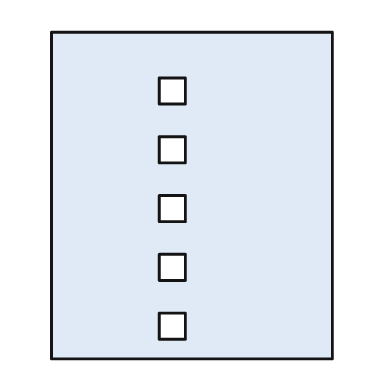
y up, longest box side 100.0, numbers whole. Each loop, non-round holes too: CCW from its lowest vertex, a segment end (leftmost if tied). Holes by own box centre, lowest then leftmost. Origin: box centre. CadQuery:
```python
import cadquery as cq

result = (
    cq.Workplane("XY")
    .moveTo(-43.0, -50.0)
    .lineTo(43.0, -50.0)
    .lineTo(43.0, 50.0)
    .lineTo(-43.0, 50.0)
    .close()
    .moveTo(-10.0, -44.0)
    .lineTo(-2.0, -44.0)
    .lineTo(-2.0, -36.0)
    .lineTo(-10.0, -36.0)
    .close()
    .moveTo(-10.0, -26.0)
    .lineTo(-2.0, -26.0)
    .lineTo(-2.0, -18.0)
    .lineTo(-10.0, -18.0)
    .close()
    .moveTo(-10.0, -8.0)
    .lineTo(-2.0, -8.0)
    .lineTo(-2.0, 0.0)
    .lineTo(-10.0, 0.0)
    .close()
    .moveTo(-10.0, 10.0)
    .lineTo(-2.0, 10.0)
    .lineTo(-2.0, 18.0)
    .lineTo(-10.0, 18.0)
    .close()
    .moveTo(-10.0, 28.0)
    .lineTo(-2.0, 28.0)
    .lineTo(-2.0, 36.0)
    .lineTo(-10.0, 36.0)
    .close()
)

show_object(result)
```